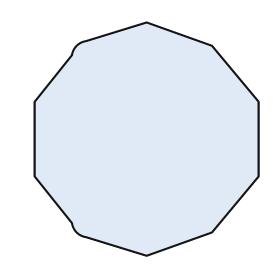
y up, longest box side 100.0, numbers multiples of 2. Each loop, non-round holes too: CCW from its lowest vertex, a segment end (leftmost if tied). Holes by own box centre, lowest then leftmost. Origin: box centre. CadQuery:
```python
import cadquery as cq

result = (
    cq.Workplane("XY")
    .moveTo(0.0, -50.0)
    .lineTo(28.0, -40.0)
    .lineTo(48.0, -16.0)
    .lineTo(48.0, 16.0)
    .lineTo(28.0, 40.0)
    .lineTo(0.0, 50.0)
    .lineTo(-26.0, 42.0)
    .threePointArc((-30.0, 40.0), (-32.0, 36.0))
    .lineTo(-48.0, 16.0)
    .lineTo(-48.0, -16.0)
    .lineTo(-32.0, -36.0)
    .threePointArc((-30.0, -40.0), (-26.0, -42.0))
    .close()
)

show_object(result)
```